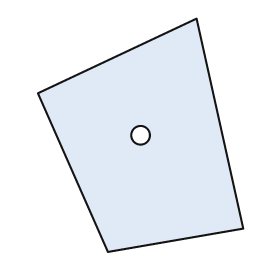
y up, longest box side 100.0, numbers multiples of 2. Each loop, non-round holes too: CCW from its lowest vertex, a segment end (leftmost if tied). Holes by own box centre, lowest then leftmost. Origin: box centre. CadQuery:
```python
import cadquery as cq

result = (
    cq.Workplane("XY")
    .moveTo(-14.0, -50.0)
    .lineTo(44.0, -40.0)
    .lineTo(24.0, 50.0)
    .lineTo(-44.0, 18.0)
    .close()
    .moveTo(0.0, 0.0)
    .circle(4.0)
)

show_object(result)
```